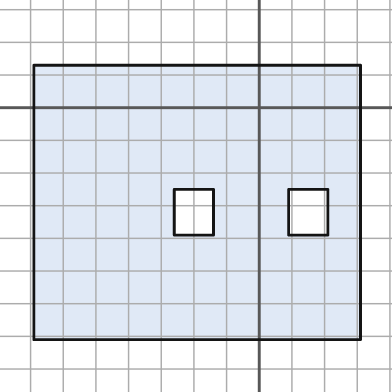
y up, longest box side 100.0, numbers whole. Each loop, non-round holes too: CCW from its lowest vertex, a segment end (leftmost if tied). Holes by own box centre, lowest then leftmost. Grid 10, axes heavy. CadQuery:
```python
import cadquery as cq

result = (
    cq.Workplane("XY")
    .moveTo(-69.0, -71.0)
    .lineTo(31.0, -71.0)
    .lineTo(31.0, 13.0)
    .lineTo(-69.0, 13.0)
    .close()
    .moveTo(-26.0, -39.0)
    .lineTo(-14.0, -39.0)
    .lineTo(-14.0, -25.0)
    .lineTo(-26.0, -25.0)
    .close()
    .moveTo(9.0, -39.0)
    .lineTo(21.0, -39.0)
    .lineTo(21.0, -25.0)
    .lineTo(9.0, -25.0)
    .close()
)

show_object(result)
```